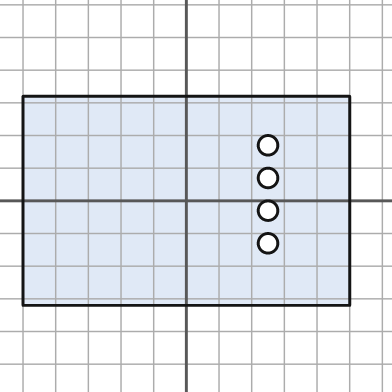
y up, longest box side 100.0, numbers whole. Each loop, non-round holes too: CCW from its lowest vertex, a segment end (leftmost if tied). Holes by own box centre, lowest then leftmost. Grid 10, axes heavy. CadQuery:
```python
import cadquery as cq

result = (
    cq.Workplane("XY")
    .moveTo(-50.0, -32.0)
    .lineTo(50.0, -32.0)
    .lineTo(50.0, 32.0)
    .lineTo(-50.0, 32.0)
    .close()
    .moveTo(25.0, -13.0)
    .circle(3.0)
    .moveTo(25.0, -3.0)
    .circle(3.0)
    .moveTo(25.0, 7.0)
    .circle(3.0)
    .moveTo(25.0, 17.0)
    .circle(3.0)
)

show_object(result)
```